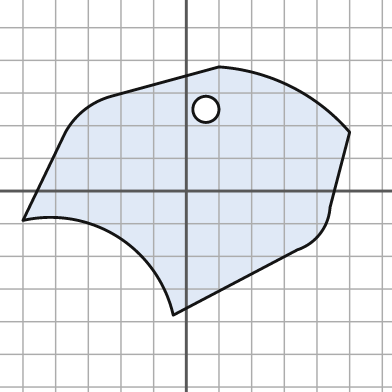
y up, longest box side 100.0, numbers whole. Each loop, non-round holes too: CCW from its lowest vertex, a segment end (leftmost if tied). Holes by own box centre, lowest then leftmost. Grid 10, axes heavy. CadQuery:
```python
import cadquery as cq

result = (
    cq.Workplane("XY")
    .moveTo(-4.0, -38.0)
    .lineTo(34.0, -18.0)
    .threePointArc((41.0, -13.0), (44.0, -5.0))
    .lineTo(50.0, 18.0)
    .threePointArc((32.0, 32.0), (10.0, 38.0))
    .lineTo(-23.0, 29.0)
    .threePointArc((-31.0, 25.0), (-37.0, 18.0))
    .lineTo(-50.0, -9.0)
    .threePointArc((-21.0, -14.0), (-4.0, -38.0))
    .close()
    .moveTo(6.0, 25.0)
    .circle(4.0)
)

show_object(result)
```